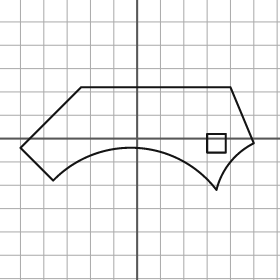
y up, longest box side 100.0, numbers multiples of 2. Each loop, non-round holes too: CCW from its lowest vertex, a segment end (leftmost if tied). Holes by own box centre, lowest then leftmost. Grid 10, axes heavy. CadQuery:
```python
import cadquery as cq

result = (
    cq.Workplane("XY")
    .moveTo(34.0, -22.0)
    .threePointArc((40.0, -10.0), (50.0, -2.0))
    .lineTo(40.0, 22.0)
    .lineTo(-24.0, 22.0)
    .lineTo(-50.0, -4.0)
    .lineTo(-36.0, -18.0)
    .threePointArc((0.0, -4.0), (34.0, -22.0))
    .close()
    .moveTo(30.0, -6.0)
    .lineTo(38.0, -6.0)
    .lineTo(38.0, 2.0)
    .lineTo(30.0, 2.0)
    .close()
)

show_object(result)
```